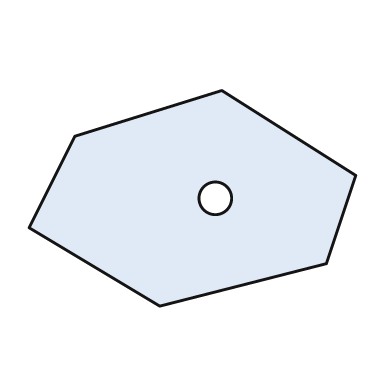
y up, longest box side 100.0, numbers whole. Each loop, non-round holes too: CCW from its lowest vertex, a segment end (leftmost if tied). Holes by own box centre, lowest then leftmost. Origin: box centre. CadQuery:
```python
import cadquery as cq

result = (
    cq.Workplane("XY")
    .moveTo(-10.0, -33.0)
    .lineTo(41.0, -20.0)
    .lineTo(50.0, 7.0)
    .lineTo(9.0, 33.0)
    .lineTo(-36.0, 19.0)
    .lineTo(-50.0, -9.0)
    .close()
    .moveTo(7.0, 0.0)
    .circle(5.0)
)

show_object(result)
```